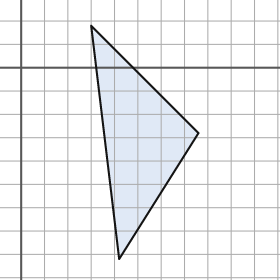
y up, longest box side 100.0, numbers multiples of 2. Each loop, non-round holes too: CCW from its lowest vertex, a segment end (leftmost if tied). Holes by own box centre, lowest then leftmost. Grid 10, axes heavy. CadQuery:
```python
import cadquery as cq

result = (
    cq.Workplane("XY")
    .moveTo(42.0, -82.0)
    .lineTo(76.0, -28.0)
    .lineTo(30.0, 18.0)
    .close()
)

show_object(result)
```